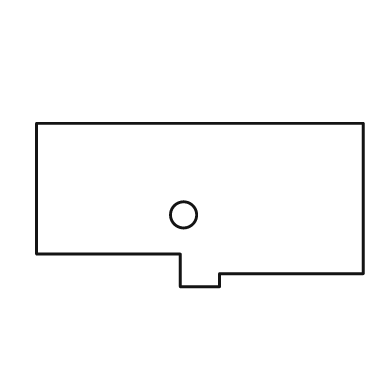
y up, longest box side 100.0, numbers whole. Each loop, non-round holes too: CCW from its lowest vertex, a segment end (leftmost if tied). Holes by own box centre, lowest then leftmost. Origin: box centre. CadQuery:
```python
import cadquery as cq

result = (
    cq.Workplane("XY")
    .moveTo(-6.0, -25.0)
    .lineTo(6.0, -25.0)
    .lineTo(6.0, -21.0)
    .lineTo(50.0, -21.0)
    .lineTo(50.0, 25.0)
    .lineTo(-50.0, 25.0)
    .lineTo(-50.0, -15.0)
    .lineTo(-6.0, -15.0)
    .close()
    .moveTo(-5.0, -3.0)
    .circle(4.0)
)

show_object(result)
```